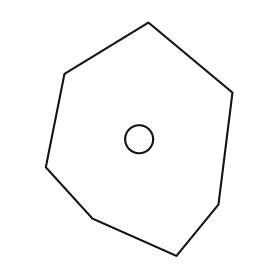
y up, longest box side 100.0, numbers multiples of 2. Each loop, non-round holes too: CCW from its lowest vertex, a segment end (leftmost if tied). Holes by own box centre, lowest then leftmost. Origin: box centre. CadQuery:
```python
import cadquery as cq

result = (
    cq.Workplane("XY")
    .moveTo(16.0, -50.0)
    .lineTo(34.0, -28.0)
    .lineTo(40.0, 20.0)
    .lineTo(4.0, 50.0)
    .lineTo(-32.0, 28.0)
    .lineTo(-40.0, -12.0)
    .lineTo(-20.0, -34.0)
    .close()
    .moveTo(0.0, 0.0)
    .circle(6.0)
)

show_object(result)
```